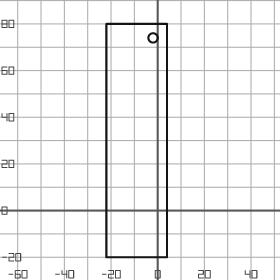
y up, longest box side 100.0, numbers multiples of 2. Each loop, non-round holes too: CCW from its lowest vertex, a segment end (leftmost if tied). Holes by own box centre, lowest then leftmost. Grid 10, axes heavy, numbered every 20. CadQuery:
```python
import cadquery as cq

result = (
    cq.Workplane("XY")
    .moveTo(-22.0, -20.0)
    .lineTo(4.0, -20.0)
    .lineTo(4.0, 80.0)
    .lineTo(-22.0, 80.0)
    .close()
    .moveTo(-2.0, 74.0)
    .circle(2.0)
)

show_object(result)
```